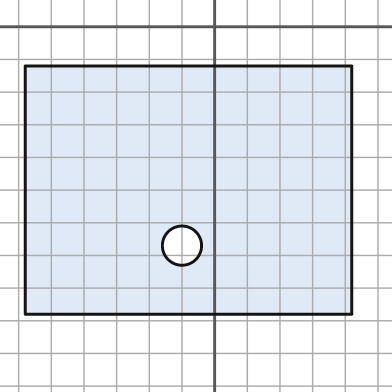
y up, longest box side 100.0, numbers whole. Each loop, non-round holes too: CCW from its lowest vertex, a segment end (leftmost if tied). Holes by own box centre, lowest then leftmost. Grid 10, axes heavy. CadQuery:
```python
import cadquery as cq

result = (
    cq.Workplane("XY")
    .moveTo(-58.0, -88.0)
    .lineTo(42.0, -88.0)
    .lineTo(42.0, -12.0)
    .lineTo(-58.0, -12.0)
    .close()
    .moveTo(-10.0, -67.0)
    .circle(6.0)
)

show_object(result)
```